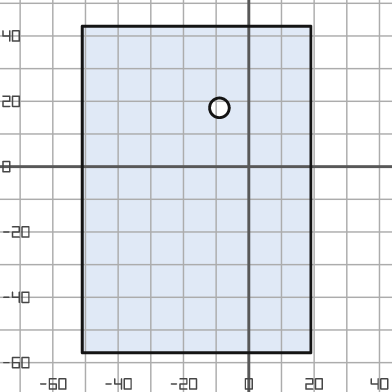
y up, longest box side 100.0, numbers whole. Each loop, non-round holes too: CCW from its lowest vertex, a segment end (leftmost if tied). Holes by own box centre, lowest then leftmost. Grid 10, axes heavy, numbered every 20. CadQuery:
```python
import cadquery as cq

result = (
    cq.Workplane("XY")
    .moveTo(-51.0, -57.0)
    .lineTo(19.0, -57.0)
    .lineTo(19.0, 43.0)
    .lineTo(-51.0, 43.0)
    .close()
    .moveTo(-9.0, 18.0)
    .circle(3.0)
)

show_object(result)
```